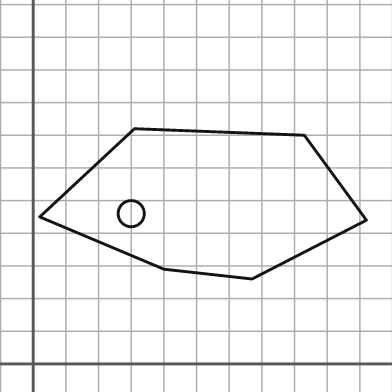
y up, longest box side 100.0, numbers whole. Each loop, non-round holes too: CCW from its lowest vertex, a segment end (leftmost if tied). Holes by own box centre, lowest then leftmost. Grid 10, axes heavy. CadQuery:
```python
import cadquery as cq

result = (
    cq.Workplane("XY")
    .moveTo(67.0, 26.0)
    .lineTo(102.0, 44.0)
    .lineTo(83.0, 70.0)
    .lineTo(31.0, 72.0)
    .lineTo(2.0, 45.0)
    .lineTo(40.0, 29.0)
    .close()
    .moveTo(30.0, 46.0)
    .circle(4.0)
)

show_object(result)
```